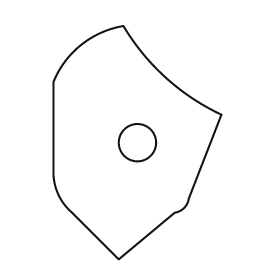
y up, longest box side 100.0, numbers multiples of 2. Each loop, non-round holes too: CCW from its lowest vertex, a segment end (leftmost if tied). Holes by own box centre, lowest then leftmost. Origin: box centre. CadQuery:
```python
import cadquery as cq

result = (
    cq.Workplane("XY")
    .moveTo(-8.0, -50.0)
    .lineTo(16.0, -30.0)
    .threePointArc((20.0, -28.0), (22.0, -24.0))
    .lineTo(36.0, 12.0)
    .threePointArc((12.0, 28.0), (-6.0, 50.0))
    .threePointArc((-24.0, 42.0), (-36.0, 26.0))
    .lineTo(-36.0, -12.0)
    .threePointArc((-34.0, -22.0), (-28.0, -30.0))
    .close()
    .moveTo(0.0, 0.0)
    .circle(8.0)
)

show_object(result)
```